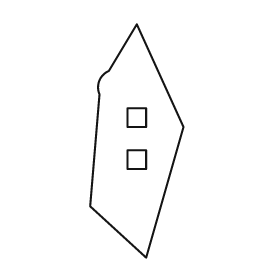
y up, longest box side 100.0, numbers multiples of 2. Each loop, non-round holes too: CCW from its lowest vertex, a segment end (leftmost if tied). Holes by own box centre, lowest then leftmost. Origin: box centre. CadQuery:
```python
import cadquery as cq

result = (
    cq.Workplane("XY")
    .moveTo(4.0, -50.0)
    .lineTo(20.0, 6.0)
    .lineTo(0.0, 50.0)
    .lineTo(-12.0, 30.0)
    .threePointArc((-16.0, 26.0), (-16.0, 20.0))
    .lineTo(-20.0, -28.0)
    .close()
    .moveTo(-4.0, -12.0)
    .lineTo(4.0, -12.0)
    .lineTo(4.0, -4.0)
    .lineTo(-4.0, -4.0)
    .close()
    .moveTo(-4.0, 6.0)
    .lineTo(4.0, 6.0)
    .lineTo(4.0, 14.0)
    .lineTo(-4.0, 14.0)
    .close()
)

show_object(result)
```